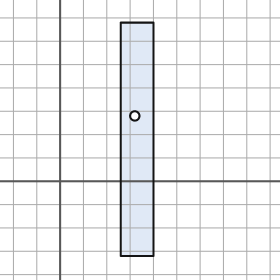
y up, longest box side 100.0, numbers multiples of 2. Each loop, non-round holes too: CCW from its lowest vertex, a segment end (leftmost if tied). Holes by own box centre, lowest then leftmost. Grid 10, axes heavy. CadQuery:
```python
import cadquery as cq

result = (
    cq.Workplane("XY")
    .moveTo(26.0, -32.0)
    .lineTo(40.0, -32.0)
    .lineTo(40.0, 68.0)
    .lineTo(26.0, 68.0)
    .close()
    .moveTo(32.0, 28.0)
    .circle(2.0)
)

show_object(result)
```